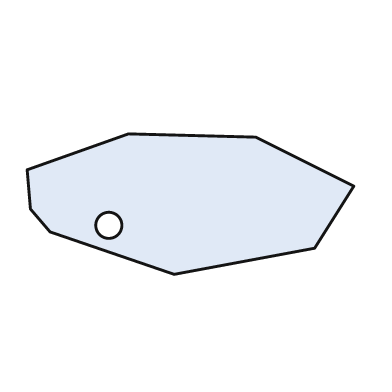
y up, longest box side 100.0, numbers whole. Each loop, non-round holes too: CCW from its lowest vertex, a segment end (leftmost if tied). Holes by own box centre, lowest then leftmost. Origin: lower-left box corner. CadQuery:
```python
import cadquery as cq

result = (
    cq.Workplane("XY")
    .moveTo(45.0, 0.0)
    .lineTo(88.0, 8.0)
    .lineTo(100.0, 27.0)
    .lineTo(70.0, 42.0)
    .lineTo(31.0, 43.0)
    .lineTo(0.0, 32.0)
    .lineTo(1.0, 20.0)
    .lineTo(7.0, 13.0)
    .close()
    .moveTo(25.0, 15.0)
    .circle(4.0)
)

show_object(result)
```